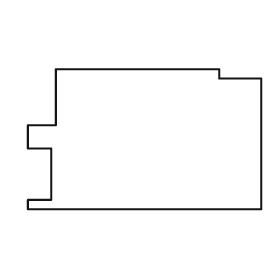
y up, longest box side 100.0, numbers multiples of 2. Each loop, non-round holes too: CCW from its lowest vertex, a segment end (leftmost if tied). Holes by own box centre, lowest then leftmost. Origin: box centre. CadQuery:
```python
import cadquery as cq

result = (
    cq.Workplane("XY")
    .moveTo(-50.0, -30.0)
    .lineTo(50.0, -30.0)
    .lineTo(50.0, 26.0)
    .lineTo(32.0, 26.0)
    .lineTo(32.0, 30.0)
    .lineTo(-38.0, 30.0)
    .lineTo(-38.0, 6.0)
    .lineTo(-50.0, 6.0)
    .lineTo(-50.0, -4.0)
    .lineTo(-40.0, -4.0)
    .lineTo(-40.0, -26.0)
    .lineTo(-50.0, -26.0)
    .close()
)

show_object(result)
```